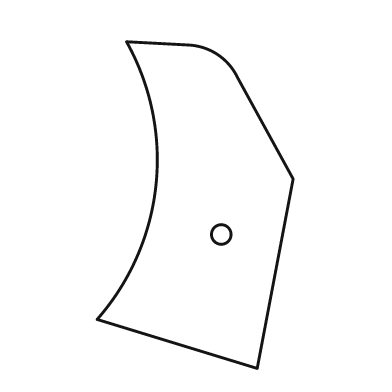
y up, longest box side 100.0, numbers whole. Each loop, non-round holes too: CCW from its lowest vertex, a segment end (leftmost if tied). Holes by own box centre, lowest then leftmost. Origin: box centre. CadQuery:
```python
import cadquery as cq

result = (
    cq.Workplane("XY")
    .moveTo(19.0, -50.0)
    .lineTo(30.0, 8.0)
    .lineTo(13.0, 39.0)
    .threePointArc((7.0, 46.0), (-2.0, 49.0))
    .lineTo(-21.0, 50.0)
    .threePointArc((-12.0, 6.0), (-30.0, -35.0))
    .close()
    .moveTo(8.0, -9.0)
    .circle(3.0)
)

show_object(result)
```